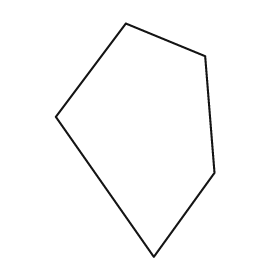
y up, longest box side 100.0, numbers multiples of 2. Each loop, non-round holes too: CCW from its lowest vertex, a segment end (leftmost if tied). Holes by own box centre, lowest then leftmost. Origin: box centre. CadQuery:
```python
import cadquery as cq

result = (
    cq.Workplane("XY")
    .moveTo(8.0, -50.0)
    .lineTo(34.0, -14.0)
    .lineTo(30.0, 36.0)
    .lineTo(-4.0, 50.0)
    .lineTo(-34.0, 10.0)
    .close()
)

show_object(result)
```